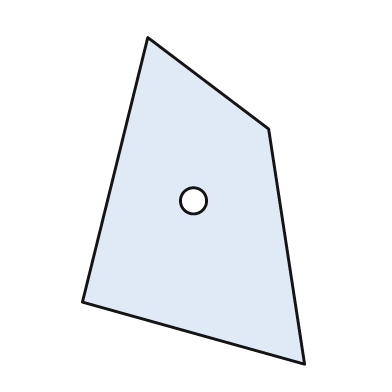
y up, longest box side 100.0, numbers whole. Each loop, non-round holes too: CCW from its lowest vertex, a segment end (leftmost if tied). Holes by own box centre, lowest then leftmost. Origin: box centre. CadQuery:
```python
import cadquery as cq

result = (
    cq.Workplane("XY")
    .moveTo(34.0, -50.0)
    .lineTo(23.0, 22.0)
    .lineTo(-14.0, 50.0)
    .lineTo(-34.0, -31.0)
    .close()
    .moveTo(0.0, 0.0)
    .circle(4.0)
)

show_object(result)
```